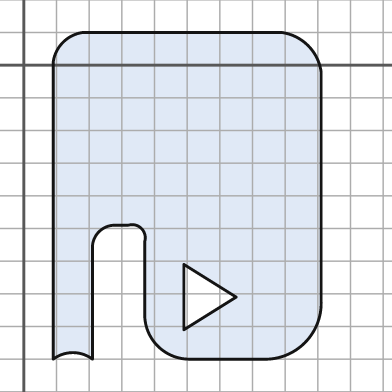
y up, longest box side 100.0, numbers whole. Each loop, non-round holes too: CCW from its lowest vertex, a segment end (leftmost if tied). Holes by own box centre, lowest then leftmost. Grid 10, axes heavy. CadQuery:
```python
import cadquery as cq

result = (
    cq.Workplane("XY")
    .moveTo(9.0, -90.0)
    .threePointArc((15.0, -88.0), (21.0, -90.0))
    .lineTo(21.0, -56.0)
    .threePointArc((23.0, -51.0), (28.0, -49.0))
    .lineTo(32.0, -49.0)
    .threePointArc((36.0, -50.0), (37.0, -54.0))
    .lineTo(37.0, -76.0)
    .threePointArc((41.0, -86.0), (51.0, -90.0))
    .lineTo(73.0, -90.0)
    .threePointArc((86.0, -85.0), (91.0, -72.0))
    .lineTo(91.0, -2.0)
    .threePointArc((87.0, 6.0), (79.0, 10.0))
    .lineTo(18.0, 10.0)
    .threePointArc((12.0, 7.0), (9.0, 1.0))
    .close()
    .moveTo(49.0, -81.0)
    .lineTo(65.0, -71.0)
    .lineTo(49.0, -61.0)
    .close()
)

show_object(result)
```